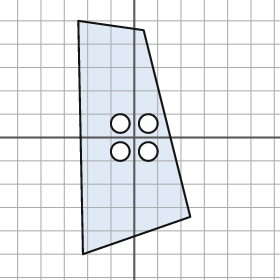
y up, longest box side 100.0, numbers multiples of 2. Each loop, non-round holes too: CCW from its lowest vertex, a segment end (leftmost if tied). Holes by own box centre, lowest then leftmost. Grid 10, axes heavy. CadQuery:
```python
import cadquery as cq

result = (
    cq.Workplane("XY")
    .moveTo(-22.0, -50.0)
    .lineTo(24.0, -34.0)
    .lineTo(4.0, 46.0)
    .lineTo(-24.0, 50.0)
    .close()
    .moveTo(-6.0, -6.0)
    .circle(4.0)
    .moveTo(6.0, -6.0)
    .circle(4.0)
    .moveTo(-6.0, 6.0)
    .circle(4.0)
    .moveTo(6.0, 6.0)
    .circle(4.0)
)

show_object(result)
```